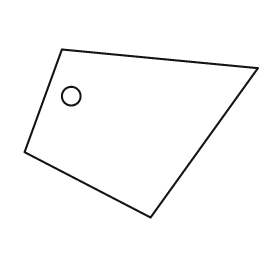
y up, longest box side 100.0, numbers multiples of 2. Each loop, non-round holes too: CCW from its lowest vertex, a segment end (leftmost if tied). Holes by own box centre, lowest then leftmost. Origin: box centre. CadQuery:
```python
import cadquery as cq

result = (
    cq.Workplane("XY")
    .moveTo(4.0, -36.0)
    .lineTo(50.0, 28.0)
    .lineTo(-34.0, 36.0)
    .lineTo(-50.0, -8.0)
    .close()
    .moveTo(-30.0, 16.0)
    .circle(4.0)
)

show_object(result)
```